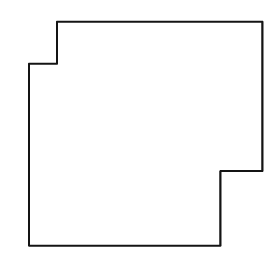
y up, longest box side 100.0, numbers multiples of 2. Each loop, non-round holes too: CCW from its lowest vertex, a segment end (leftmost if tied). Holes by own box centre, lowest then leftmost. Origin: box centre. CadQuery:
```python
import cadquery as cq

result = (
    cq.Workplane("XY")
    .moveTo(-50.0, -48.0)
    .lineTo(32.0, -48.0)
    .lineTo(32.0, -16.0)
    .lineTo(50.0, -16.0)
    .lineTo(50.0, 48.0)
    .lineTo(-38.0, 48.0)
    .lineTo(-38.0, 30.0)
    .lineTo(-50.0, 30.0)
    .close()
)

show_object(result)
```